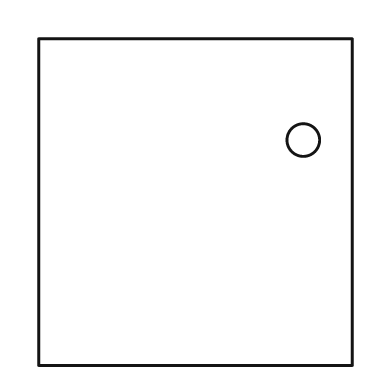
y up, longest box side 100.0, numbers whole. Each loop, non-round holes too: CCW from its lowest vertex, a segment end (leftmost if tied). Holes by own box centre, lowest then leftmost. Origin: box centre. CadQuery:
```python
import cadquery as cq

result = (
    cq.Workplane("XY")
    .moveTo(-48.0, -50.0)
    .lineTo(48.0, -50.0)
    .lineTo(48.0, 50.0)
    .lineTo(-48.0, 50.0)
    .close()
    .moveTo(33.0, 19.0)
    .circle(5.0)
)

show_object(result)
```